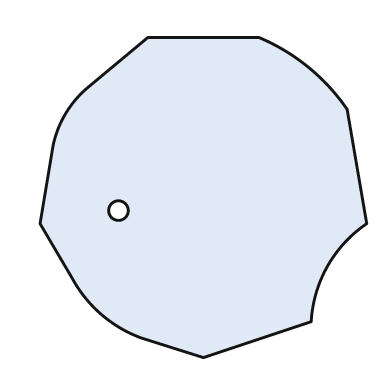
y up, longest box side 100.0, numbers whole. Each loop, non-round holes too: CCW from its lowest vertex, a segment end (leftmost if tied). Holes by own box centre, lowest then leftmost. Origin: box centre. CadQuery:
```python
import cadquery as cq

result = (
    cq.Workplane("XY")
    .moveTo(0.0, -49.0)
    .lineTo(33.0, -38.0)
    .threePointArc((38.0, -21.0), (50.0, -8.0))
    .lineTo(44.0, 27.0)
    .threePointArc((32.0, 40.0), (17.0, 49.0))
    .lineTo(-17.0, 49.0)
    .lineTo(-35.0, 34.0)
    .threePointArc((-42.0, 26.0), (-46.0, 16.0))
    .lineTo(-50.0, -8.0)
    .lineTo(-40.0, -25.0)
    .threePointArc((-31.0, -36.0), (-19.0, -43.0))
    .close()
    .moveTo(-26.0, -4.0)
    .circle(3.0)
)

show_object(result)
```